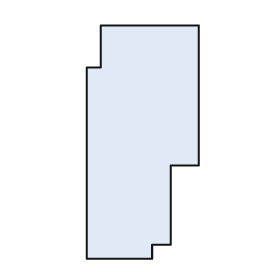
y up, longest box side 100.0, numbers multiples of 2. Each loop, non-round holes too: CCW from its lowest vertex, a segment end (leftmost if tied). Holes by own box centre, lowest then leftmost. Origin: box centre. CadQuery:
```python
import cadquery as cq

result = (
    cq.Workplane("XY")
    .moveTo(-24.0, -50.0)
    .lineTo(4.0, -50.0)
    .lineTo(4.0, -44.0)
    .lineTo(12.0, -44.0)
    .lineTo(12.0, -10.0)
    .lineTo(24.0, -10.0)
    .lineTo(24.0, 50.0)
    .lineTo(-18.0, 50.0)
    .lineTo(-18.0, 32.0)
    .lineTo(-24.0, 32.0)
    .close()
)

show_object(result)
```